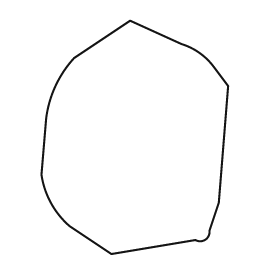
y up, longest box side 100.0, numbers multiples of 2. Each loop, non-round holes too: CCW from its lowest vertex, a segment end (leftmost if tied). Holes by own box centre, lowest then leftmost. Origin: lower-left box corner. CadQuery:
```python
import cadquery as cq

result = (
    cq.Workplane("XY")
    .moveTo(30.0, 0.0)
    .lineTo(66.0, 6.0)
    .threePointArc((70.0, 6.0), (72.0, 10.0))
    .lineTo(76.0, 22.0)
    .lineTo(80.0, 72.0)
    .lineTo(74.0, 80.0)
    .threePointArc((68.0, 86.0), (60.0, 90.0))
    .lineTo(38.0, 100.0)
    .lineTo(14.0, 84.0)
    .threePointArc((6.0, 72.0), (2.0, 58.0))
    .lineTo(0.0, 34.0)
    .threePointArc((4.0, 22.0), (12.0, 12.0))
    .close()
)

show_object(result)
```